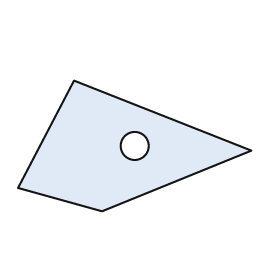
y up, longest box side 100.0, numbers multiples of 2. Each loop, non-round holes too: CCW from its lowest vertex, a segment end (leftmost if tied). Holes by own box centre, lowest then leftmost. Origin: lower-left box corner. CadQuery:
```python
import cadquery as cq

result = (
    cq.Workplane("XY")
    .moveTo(36.0, 0.0)
    .lineTo(100.0, 26.0)
    .lineTo(24.0, 56.0)
    .lineTo(0.0, 10.0)
    .close()
    .moveTo(50.0, 28.0)
    .circle(6.0)
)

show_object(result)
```